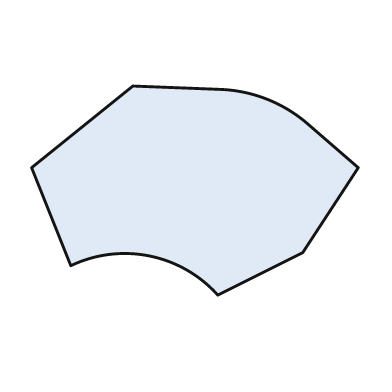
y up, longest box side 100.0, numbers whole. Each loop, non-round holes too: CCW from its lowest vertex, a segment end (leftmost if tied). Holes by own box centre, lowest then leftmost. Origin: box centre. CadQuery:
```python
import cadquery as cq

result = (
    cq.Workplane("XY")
    .moveTo(7.0, -32.0)
    .lineTo(33.0, -19.0)
    .lineTo(50.0, 7.0)
    .lineTo(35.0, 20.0)
    .threePointArc((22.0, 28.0), (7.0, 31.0))
    .lineTo(-19.0, 32.0)
    .lineTo(-50.0, 7.0)
    .lineTo(-38.0, -23.0)
    .threePointArc((-14.0, -20.0), (7.0, -32.0))
    .close()
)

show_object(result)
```